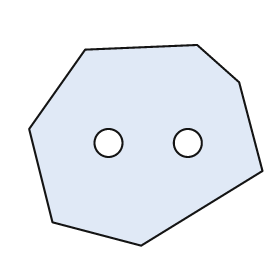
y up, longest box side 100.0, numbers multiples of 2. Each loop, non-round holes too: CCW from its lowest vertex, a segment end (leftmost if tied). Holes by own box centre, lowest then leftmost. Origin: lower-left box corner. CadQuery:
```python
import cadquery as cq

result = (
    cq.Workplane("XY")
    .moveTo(48.0, 0.0)
    .lineTo(100.0, 32.0)
    .lineTo(90.0, 70.0)
    .lineTo(72.0, 86.0)
    .lineTo(24.0, 84.0)
    .lineTo(0.0, 50.0)
    .lineTo(10.0, 10.0)
    .close()
    .moveTo(34.0, 44.0)
    .circle(6.0)
    .moveTo(68.0, 44.0)
    .circle(6.0)
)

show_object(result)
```